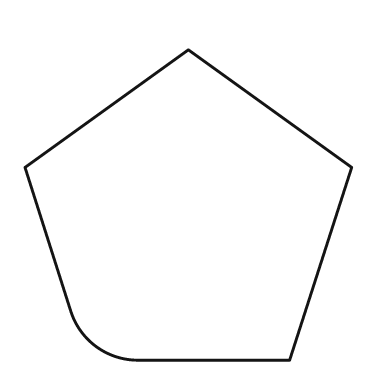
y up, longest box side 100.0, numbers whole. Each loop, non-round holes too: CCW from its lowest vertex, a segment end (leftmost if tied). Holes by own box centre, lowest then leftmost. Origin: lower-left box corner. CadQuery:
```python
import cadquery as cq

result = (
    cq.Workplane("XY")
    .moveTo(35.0, 0.0)
    .lineTo(81.0, 0.0)
    .lineTo(100.0, 59.0)
    .lineTo(50.0, 95.0)
    .lineTo(0.0, 59.0)
    .lineTo(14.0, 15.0)
    .threePointArc((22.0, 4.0), (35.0, 0.0))
    .close()
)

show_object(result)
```